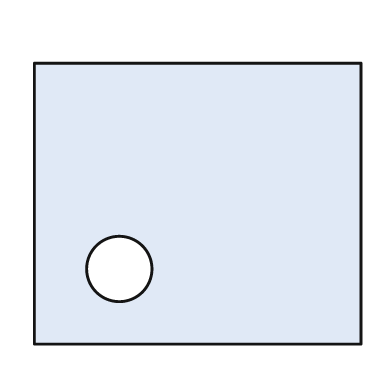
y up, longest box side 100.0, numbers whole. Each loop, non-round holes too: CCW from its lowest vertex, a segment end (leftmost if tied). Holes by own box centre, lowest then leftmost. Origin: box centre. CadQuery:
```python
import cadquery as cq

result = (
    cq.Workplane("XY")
    .moveTo(-50.0, -43.0)
    .lineTo(50.0, -43.0)
    .lineTo(50.0, 43.0)
    .lineTo(-50.0, 43.0)
    .close()
    .moveTo(-24.0, -20.0)
    .circle(10.0)
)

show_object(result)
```